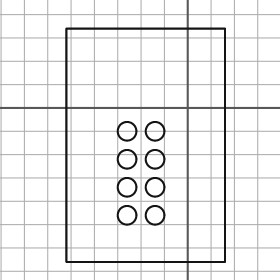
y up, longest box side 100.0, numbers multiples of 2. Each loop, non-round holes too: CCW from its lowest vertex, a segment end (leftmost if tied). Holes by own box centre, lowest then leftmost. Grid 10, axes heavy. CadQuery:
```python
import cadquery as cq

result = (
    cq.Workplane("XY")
    .moveTo(-52.0, -66.0)
    .lineTo(16.0, -66.0)
    .lineTo(16.0, 34.0)
    .lineTo(-52.0, 34.0)
    .close()
    .moveTo(-26.0, -46.0)
    .circle(4.0)
    .moveTo(-14.0, -46.0)
    .circle(4.0)
    .moveTo(-26.0, -34.0)
    .circle(4.0)
    .moveTo(-14.0, -34.0)
    .circle(4.0)
    .moveTo(-26.0, -22.0)
    .circle(4.0)
    .moveTo(-14.0, -22.0)
    .circle(4.0)
    .moveTo(-26.0, -10.0)
    .circle(4.0)
    .moveTo(-14.0, -10.0)
    .circle(4.0)
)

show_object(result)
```